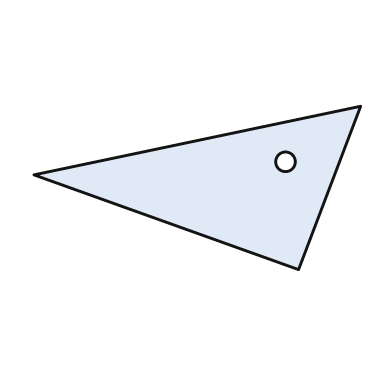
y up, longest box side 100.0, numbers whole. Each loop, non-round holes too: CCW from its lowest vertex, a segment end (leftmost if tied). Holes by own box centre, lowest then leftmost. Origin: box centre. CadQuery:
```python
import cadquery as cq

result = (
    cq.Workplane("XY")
    .moveTo(31.0, -25.0)
    .lineTo(50.0, 25.0)
    .lineTo(-50.0, 4.0)
    .close()
    .moveTo(27.0, 8.0)
    .circle(3.0)
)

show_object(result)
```